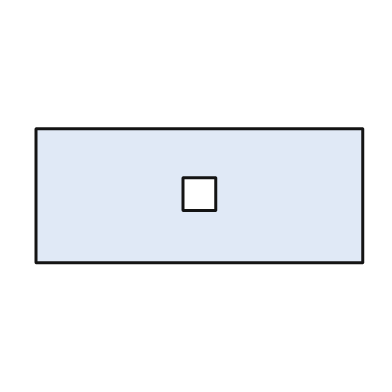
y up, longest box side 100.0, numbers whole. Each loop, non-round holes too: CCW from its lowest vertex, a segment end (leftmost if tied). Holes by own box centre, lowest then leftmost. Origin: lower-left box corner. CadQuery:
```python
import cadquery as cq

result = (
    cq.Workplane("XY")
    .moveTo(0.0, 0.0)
    .lineTo(100.0, 0.0)
    .lineTo(100.0, 41.0)
    .lineTo(0.0, 41.0)
    .close()
    .moveTo(45.0, 16.0)
    .lineTo(55.0, 16.0)
    .lineTo(55.0, 26.0)
    .lineTo(45.0, 26.0)
    .close()
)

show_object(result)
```